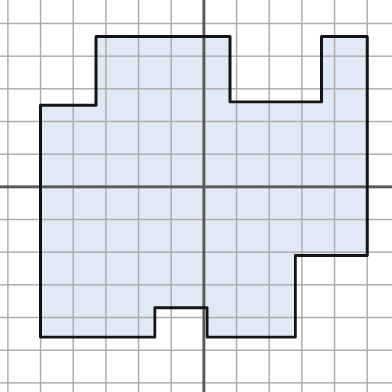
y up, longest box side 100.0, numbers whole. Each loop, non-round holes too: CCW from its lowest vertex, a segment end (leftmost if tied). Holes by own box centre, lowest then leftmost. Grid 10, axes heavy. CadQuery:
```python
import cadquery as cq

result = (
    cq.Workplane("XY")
    .moveTo(-50.0, -46.0)
    .lineTo(-15.0, -46.0)
    .lineTo(-15.0, -37.0)
    .lineTo(1.0, -37.0)
    .lineTo(1.0, -46.0)
    .lineTo(28.0, -46.0)
    .lineTo(28.0, -21.0)
    .lineTo(50.0, -21.0)
    .lineTo(50.0, 46.0)
    .lineTo(36.0, 46.0)
    .lineTo(36.0, 26.0)
    .lineTo(8.0, 26.0)
    .lineTo(8.0, 46.0)
    .lineTo(-33.0, 46.0)
    .lineTo(-33.0, 25.0)
    .lineTo(-50.0, 25.0)
    .close()
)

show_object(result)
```